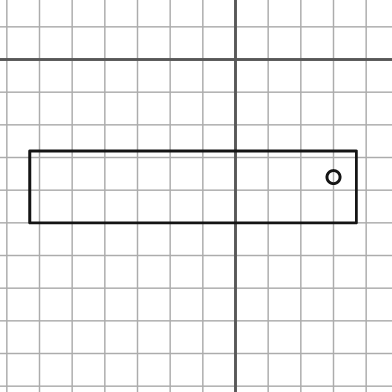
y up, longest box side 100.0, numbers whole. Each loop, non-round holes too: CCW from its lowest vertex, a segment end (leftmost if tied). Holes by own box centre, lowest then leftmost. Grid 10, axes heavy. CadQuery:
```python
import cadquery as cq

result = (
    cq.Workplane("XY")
    .moveTo(-63.0, -50.0)
    .lineTo(37.0, -50.0)
    .lineTo(37.0, -28.0)
    .lineTo(-63.0, -28.0)
    .close()
    .moveTo(30.0, -36.0)
    .circle(2.0)
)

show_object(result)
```